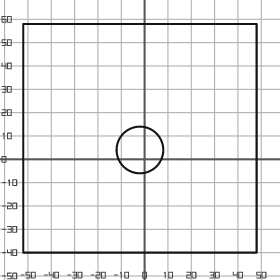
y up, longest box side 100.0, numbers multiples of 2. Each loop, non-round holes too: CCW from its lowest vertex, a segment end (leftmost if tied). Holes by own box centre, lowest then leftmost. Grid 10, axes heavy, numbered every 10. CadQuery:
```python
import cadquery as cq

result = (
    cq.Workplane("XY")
    .moveTo(-52.0, -40.0)
    .lineTo(48.0, -40.0)
    .lineTo(48.0, 58.0)
    .lineTo(-52.0, 58.0)
    .close()
    .moveTo(-2.0, 4.0)
    .circle(10.0)
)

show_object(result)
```